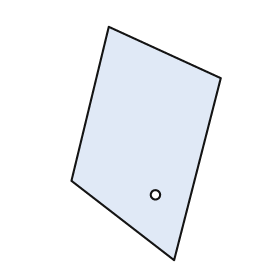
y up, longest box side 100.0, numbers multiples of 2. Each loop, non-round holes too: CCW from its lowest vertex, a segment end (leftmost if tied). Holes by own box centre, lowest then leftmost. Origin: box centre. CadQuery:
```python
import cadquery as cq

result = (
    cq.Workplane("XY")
    .moveTo(12.0, -50.0)
    .lineTo(32.0, 28.0)
    .lineTo(-16.0, 50.0)
    .lineTo(-32.0, -16.0)
    .close()
    .moveTo(4.0, -22.0)
    .circle(2.0)
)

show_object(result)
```